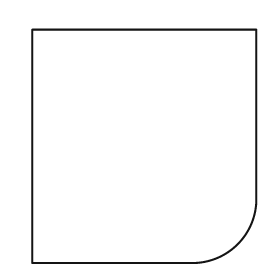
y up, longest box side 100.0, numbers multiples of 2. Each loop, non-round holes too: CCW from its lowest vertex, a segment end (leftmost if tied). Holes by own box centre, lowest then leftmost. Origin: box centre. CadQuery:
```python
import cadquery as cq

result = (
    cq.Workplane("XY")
    .moveTo(-48.0, -50.0)
    .lineTo(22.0, -50.0)
    .threePointArc((40.0, -42.0), (48.0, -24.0))
    .lineTo(48.0, 50.0)
    .lineTo(-48.0, 50.0)
    .close()
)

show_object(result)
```